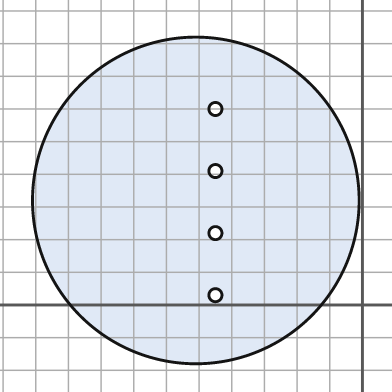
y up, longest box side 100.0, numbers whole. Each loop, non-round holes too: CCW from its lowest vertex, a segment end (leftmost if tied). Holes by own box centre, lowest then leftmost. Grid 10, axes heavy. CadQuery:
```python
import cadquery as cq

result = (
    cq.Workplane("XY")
    .moveTo(-51.0, 32.0)
    .circle(50.0)
    .moveTo(-45.0, 3.0)
    .circle(2.0)
    .moveTo(-45.0, 22.0)
    .circle(2.0)
    .moveTo(-45.0, 41.0)
    .circle(2.0)
    .moveTo(-45.0, 60.0)
    .circle(2.0)
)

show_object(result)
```